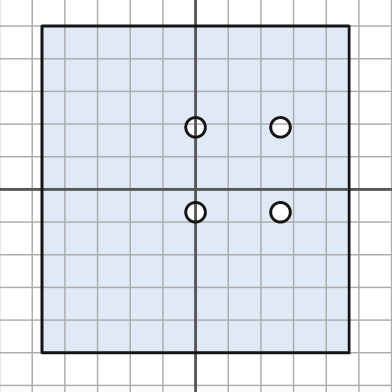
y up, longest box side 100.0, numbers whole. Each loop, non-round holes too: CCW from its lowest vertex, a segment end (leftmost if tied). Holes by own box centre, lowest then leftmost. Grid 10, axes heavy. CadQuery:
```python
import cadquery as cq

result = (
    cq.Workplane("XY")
    .moveTo(-47.0, -50.0)
    .lineTo(47.0, -50.0)
    .lineTo(47.0, 50.0)
    .lineTo(-47.0, 50.0)
    .close()
    .moveTo(0.0, -7.0)
    .circle(3.0)
    .moveTo(26.0, -7.0)
    .circle(3.0)
    .moveTo(0.0, 19.0)
    .circle(3.0)
    .moveTo(26.0, 19.0)
    .circle(3.0)
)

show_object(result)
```